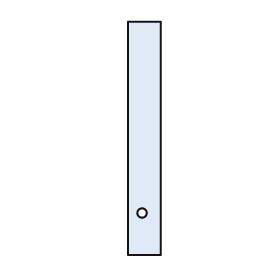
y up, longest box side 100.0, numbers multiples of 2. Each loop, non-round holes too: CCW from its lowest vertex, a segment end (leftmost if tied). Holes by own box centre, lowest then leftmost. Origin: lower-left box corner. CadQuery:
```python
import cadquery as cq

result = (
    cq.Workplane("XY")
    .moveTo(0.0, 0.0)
    .lineTo(14.0, 0.0)
    .lineTo(14.0, 100.0)
    .lineTo(0.0, 100.0)
    .close()
    .moveTo(6.0, 18.0)
    .circle(2.0)
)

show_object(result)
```